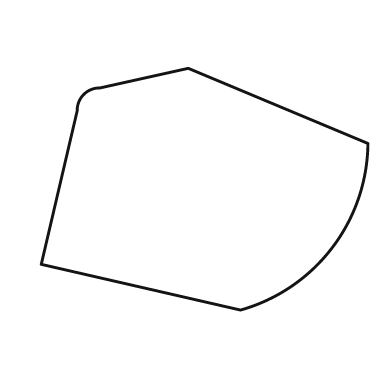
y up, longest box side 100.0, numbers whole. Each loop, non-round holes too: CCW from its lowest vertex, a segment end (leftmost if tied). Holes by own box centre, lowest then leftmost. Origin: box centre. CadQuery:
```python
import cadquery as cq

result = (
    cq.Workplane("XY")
    .moveTo(11.0, -37.0)
    .threePointArc((39.0, -18.0), (50.0, 14.0))
    .lineTo(-5.0, 37.0)
    .lineTo(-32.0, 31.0)
    .threePointArc((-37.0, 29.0), (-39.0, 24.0))
    .lineTo(-50.0, -23.0)
    .close()
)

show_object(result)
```